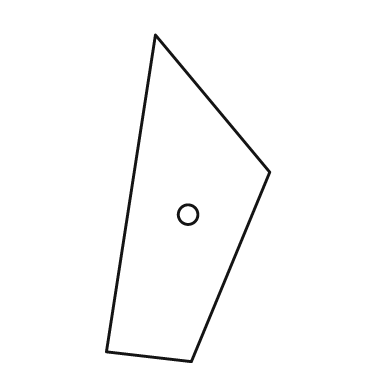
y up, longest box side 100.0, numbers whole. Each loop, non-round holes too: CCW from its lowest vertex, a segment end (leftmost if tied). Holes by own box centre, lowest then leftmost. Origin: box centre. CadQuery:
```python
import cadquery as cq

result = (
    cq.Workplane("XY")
    .moveTo(1.0, -50.0)
    .lineTo(25.0, 8.0)
    .lineTo(-10.0, 50.0)
    .lineTo(-25.0, -47.0)
    .close()
    .moveTo(0.0, -5.0)
    .circle(3.0)
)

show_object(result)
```